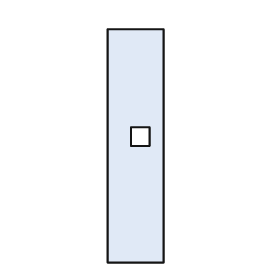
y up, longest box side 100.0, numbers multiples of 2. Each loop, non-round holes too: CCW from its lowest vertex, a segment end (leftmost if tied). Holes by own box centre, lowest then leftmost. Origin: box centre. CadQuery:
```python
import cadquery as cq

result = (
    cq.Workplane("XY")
    .moveTo(-12.0, -50.0)
    .lineTo(12.0, -50.0)
    .lineTo(12.0, 50.0)
    .lineTo(-12.0, 50.0)
    .close()
    .moveTo(-2.0, 0.0)
    .lineTo(6.0, 0.0)
    .lineTo(6.0, 8.0)
    .lineTo(-2.0, 8.0)
    .close()
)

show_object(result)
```